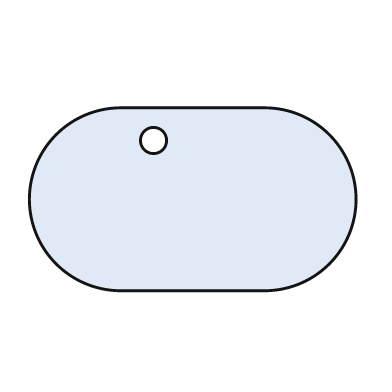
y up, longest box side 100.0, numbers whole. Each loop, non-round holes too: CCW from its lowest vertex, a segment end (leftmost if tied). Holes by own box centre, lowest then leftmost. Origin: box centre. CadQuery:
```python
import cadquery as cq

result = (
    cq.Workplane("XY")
    .moveTo(-22.0, -28.0)
    .lineTo(22.0, -28.0)
    .threePointArc((50.0, 0.0), (22.0, 28.0))
    .lineTo(-22.0, 28.0)
    .threePointArc((-50.0, 0.0), (-22.0, -28.0))
    .close()
    .moveTo(-12.0, 18.0)
    .circle(4.0)
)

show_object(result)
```